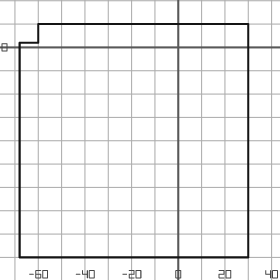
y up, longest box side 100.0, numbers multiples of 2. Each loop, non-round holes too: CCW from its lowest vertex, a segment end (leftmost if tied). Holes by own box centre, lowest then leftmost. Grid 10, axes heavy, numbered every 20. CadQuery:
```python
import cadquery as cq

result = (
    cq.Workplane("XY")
    .moveTo(-68.0, -90.0)
    .lineTo(30.0, -90.0)
    .lineTo(30.0, 10.0)
    .lineTo(-60.0, 10.0)
    .lineTo(-60.0, 2.0)
    .lineTo(-68.0, 2.0)
    .close()
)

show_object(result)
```